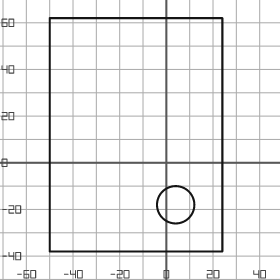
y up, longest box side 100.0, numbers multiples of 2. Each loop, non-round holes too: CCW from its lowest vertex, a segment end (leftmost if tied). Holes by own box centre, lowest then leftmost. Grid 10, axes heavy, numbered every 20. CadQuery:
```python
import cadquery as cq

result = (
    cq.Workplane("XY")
    .moveTo(-50.0, -38.0)
    .lineTo(24.0, -38.0)
    .lineTo(24.0, 62.0)
    .lineTo(-50.0, 62.0)
    .close()
    .moveTo(4.0, -18.0)
    .circle(8.0)
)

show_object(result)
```